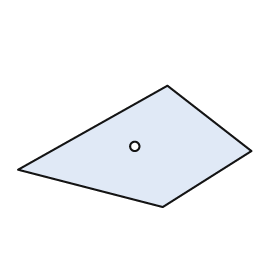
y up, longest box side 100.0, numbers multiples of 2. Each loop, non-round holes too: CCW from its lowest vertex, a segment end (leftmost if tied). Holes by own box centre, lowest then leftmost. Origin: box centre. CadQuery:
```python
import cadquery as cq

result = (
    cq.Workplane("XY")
    .moveTo(12.0, -26.0)
    .lineTo(50.0, -2.0)
    .lineTo(14.0, 26.0)
    .lineTo(-50.0, -10.0)
    .close()
    .moveTo(0.0, 0.0)
    .circle(2.0)
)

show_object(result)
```